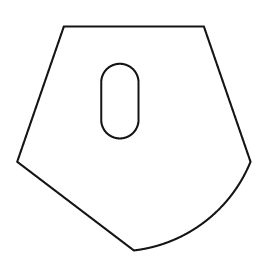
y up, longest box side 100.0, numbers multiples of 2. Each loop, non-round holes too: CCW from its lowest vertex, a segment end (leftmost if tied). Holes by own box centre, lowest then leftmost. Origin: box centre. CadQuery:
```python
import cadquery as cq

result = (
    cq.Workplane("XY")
    .moveTo(0.0, -48.0)
    .threePointArc((30.0, -36.0), (50.0, -10.0))
    .lineTo(30.0, 48.0)
    .lineTo(-30.0, 48.0)
    .lineTo(-50.0, -10.0)
    .close()
    .moveTo(-14.0, 8.0)
    .threePointArc((-6.0, 0.0), (2.0, 8.0))
    .lineTo(2.0, 24.0)
    .threePointArc((-6.0, 32.0), (-14.0, 24.0))
    .close()
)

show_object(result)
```